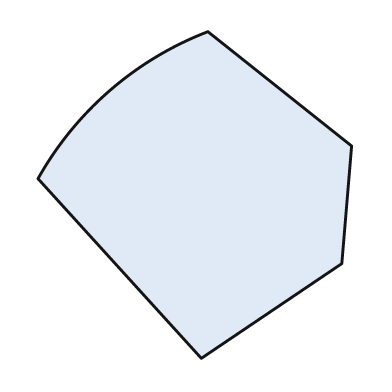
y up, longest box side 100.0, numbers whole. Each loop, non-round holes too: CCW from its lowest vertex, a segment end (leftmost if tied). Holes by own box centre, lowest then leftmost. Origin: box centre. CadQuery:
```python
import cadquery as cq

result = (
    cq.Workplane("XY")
    .moveTo(2.0, -50.0)
    .lineTo(45.0, -21.0)
    .lineTo(48.0, 15.0)
    .lineTo(4.0, 50.0)
    .threePointArc((-26.0, 32.0), (-48.0, 5.0))
    .close()
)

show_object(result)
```